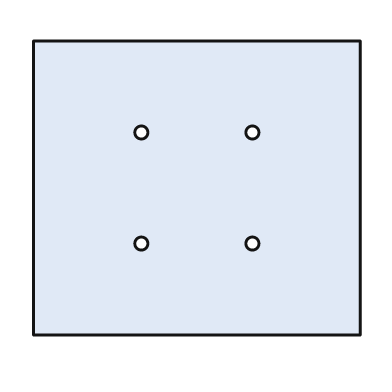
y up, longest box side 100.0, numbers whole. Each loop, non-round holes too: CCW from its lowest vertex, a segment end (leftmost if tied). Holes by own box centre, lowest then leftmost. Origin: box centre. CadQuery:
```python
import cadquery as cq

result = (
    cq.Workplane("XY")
    .moveTo(-50.0, -45.0)
    .lineTo(50.0, -45.0)
    .lineTo(50.0, 45.0)
    .lineTo(-50.0, 45.0)
    .close()
    .moveTo(-17.0, -17.0)
    .circle(2.0)
    .moveTo(17.0, -17.0)
    .circle(2.0)
    .moveTo(-17.0, 17.0)
    .circle(2.0)
    .moveTo(17.0, 17.0)
    .circle(2.0)
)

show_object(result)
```